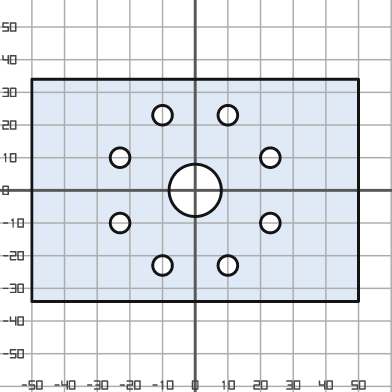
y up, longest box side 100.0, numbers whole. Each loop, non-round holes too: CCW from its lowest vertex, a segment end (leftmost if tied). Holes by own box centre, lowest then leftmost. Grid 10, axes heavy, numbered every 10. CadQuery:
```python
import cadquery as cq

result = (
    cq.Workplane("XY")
    .moveTo(-50.0, -34.0)
    .lineTo(50.0, -34.0)
    .lineTo(50.0, 34.0)
    .lineTo(-50.0, 34.0)
    .close()
    .moveTo(-10.0, -23.0)
    .circle(3.0)
    .moveTo(10.0, -23.0)
    .circle(3.0)
    .moveTo(-23.0, -10.0)
    .circle(3.0)
    .moveTo(23.0, -10.0)
    .circle(3.0)
    .moveTo(0.0, 0.0)
    .circle(8.0)
    .moveTo(-23.0, 10.0)
    .circle(3.0)
    .moveTo(23.0, 10.0)
    .circle(3.0)
    .moveTo(-10.0, 23.0)
    .circle(3.0)
    .moveTo(10.0, 23.0)
    .circle(3.0)
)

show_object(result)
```